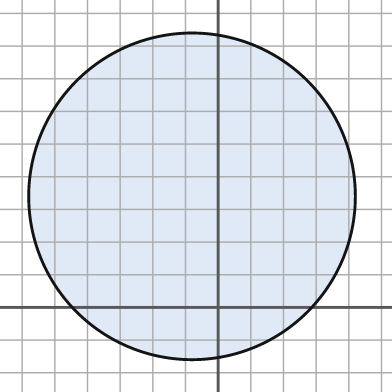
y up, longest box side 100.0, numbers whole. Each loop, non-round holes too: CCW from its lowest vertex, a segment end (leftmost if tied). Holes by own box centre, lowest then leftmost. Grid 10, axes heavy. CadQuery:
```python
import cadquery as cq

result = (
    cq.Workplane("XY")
    .moveTo(-8.0, 34.0)
    .circle(50.0)
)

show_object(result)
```